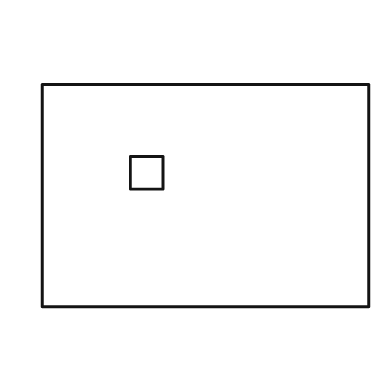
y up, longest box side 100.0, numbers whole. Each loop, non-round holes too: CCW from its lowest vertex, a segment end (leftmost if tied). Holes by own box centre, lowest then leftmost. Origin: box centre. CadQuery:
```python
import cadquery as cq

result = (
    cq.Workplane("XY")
    .moveTo(-50.0, -34.0)
    .lineTo(50.0, -34.0)
    .lineTo(50.0, 34.0)
    .lineTo(-50.0, 34.0)
    .close()
    .moveTo(-23.0, 2.0)
    .lineTo(-13.0, 2.0)
    .lineTo(-13.0, 12.0)
    .lineTo(-23.0, 12.0)
    .close()
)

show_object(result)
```